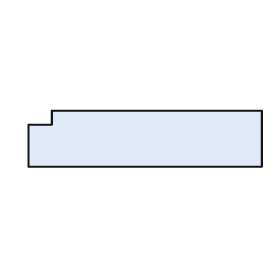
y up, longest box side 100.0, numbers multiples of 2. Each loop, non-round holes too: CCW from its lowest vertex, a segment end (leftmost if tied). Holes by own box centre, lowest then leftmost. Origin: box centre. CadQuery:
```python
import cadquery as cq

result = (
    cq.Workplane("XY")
    .moveTo(-50.0, -12.0)
    .lineTo(50.0, -12.0)
    .lineTo(50.0, 12.0)
    .lineTo(-40.0, 12.0)
    .lineTo(-40.0, 6.0)
    .lineTo(-50.0, 6.0)
    .close()
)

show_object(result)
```